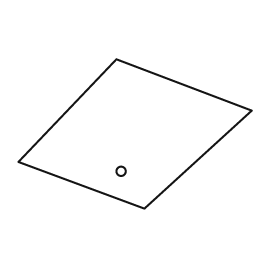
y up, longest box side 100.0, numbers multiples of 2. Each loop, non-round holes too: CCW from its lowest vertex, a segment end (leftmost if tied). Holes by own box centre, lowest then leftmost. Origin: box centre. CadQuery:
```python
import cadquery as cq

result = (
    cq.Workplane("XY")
    .moveTo(4.0, -32.0)
    .lineTo(50.0, 10.0)
    .lineTo(-8.0, 32.0)
    .lineTo(-50.0, -12.0)
    .close()
    .moveTo(-6.0, -16.0)
    .circle(2.0)
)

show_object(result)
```